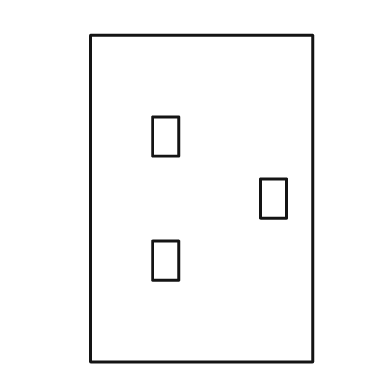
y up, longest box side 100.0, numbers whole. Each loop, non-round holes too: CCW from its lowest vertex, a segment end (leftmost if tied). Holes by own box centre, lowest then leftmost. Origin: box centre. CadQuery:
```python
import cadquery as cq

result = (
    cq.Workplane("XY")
    .moveTo(-34.0, -50.0)
    .lineTo(34.0, -50.0)
    .lineTo(34.0, 50.0)
    .lineTo(-34.0, 50.0)
    .close()
    .moveTo(-15.0, -25.0)
    .lineTo(-7.0, -25.0)
    .lineTo(-7.0, -13.0)
    .lineTo(-15.0, -13.0)
    .close()
    .moveTo(18.0, -6.0)
    .lineTo(26.0, -6.0)
    .lineTo(26.0, 6.0)
    .lineTo(18.0, 6.0)
    .close()
    .moveTo(-15.0, 13.0)
    .lineTo(-7.0, 13.0)
    .lineTo(-7.0, 25.0)
    .lineTo(-15.0, 25.0)
    .close()
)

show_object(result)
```